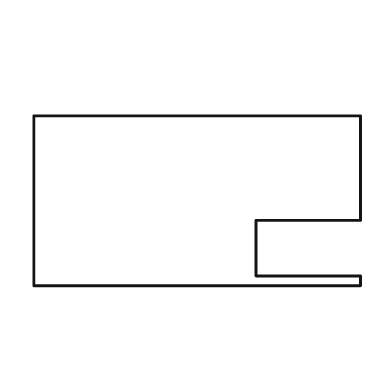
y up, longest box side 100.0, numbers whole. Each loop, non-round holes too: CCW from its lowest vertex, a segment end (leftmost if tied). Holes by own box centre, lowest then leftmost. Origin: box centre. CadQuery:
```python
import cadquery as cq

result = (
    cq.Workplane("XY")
    .moveTo(-50.0, -26.0)
    .lineTo(50.0, -26.0)
    .lineTo(50.0, -23.0)
    .lineTo(18.0, -23.0)
    .lineTo(18.0, -6.0)
    .lineTo(50.0, -6.0)
    .lineTo(50.0, 26.0)
    .lineTo(-50.0, 26.0)
    .close()
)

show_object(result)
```